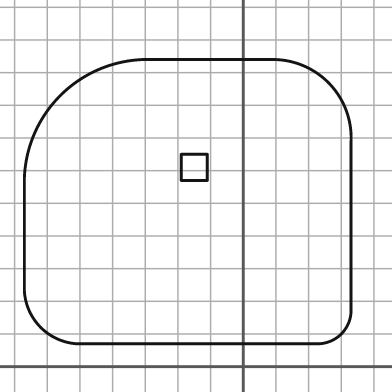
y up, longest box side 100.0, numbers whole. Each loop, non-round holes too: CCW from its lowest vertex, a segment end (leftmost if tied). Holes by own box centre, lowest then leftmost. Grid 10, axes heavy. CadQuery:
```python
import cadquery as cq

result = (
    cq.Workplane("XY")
    .moveTo(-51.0, 7.0)
    .lineTo(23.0, 7.0)
    .threePointArc((30.0, 10.0), (33.0, 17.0))
    .lineTo(33.0, 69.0)
    .threePointArc((26.0, 87.0), (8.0, 94.0))
    .lineTo(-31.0, 94.0)
    .threePointArc((-56.0, 83.0), (-67.0, 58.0))
    .lineTo(-67.0, 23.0)
    .threePointArc((-62.0, 12.0), (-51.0, 7.0))
    .close()
    .moveTo(-19.0, 57.0)
    .lineTo(-11.0, 57.0)
    .lineTo(-11.0, 65.0)
    .lineTo(-19.0, 65.0)
    .close()
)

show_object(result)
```